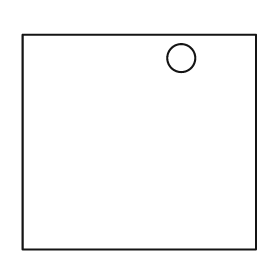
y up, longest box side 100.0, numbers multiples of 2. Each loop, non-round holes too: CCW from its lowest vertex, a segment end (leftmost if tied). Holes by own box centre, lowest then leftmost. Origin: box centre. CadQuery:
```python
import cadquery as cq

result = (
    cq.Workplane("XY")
    .moveTo(-50.0, -46.0)
    .lineTo(50.0, -46.0)
    .lineTo(50.0, 46.0)
    .lineTo(-50.0, 46.0)
    .close()
    .moveTo(18.0, 36.0)
    .circle(6.0)
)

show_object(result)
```